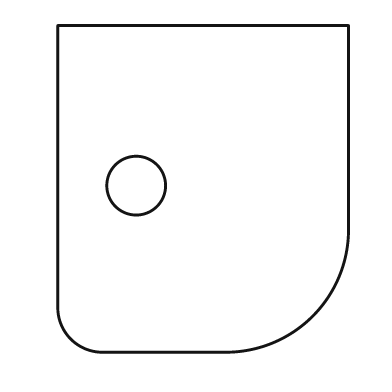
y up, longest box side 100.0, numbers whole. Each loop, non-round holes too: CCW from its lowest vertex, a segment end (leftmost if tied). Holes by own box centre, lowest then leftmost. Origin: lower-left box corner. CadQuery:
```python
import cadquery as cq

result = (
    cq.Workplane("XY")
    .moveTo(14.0, 0.0)
    .lineTo(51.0, 0.0)
    .threePointArc((78.0, 11.0), (89.0, 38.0))
    .lineTo(89.0, 100.0)
    .lineTo(0.0, 100.0)
    .lineTo(0.0, 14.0)
    .threePointArc((4.0, 4.0), (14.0, 0.0))
    .close()
    .moveTo(24.0, 51.0)
    .circle(9.0)
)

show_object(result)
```